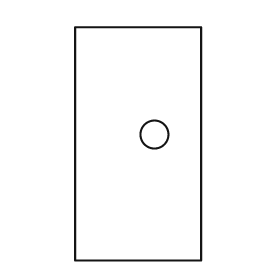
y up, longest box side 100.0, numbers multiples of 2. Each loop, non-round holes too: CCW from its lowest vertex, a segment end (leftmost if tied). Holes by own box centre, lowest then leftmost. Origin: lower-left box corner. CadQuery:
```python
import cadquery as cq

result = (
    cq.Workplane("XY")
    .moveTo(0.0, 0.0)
    .lineTo(54.0, 0.0)
    .lineTo(54.0, 100.0)
    .lineTo(0.0, 100.0)
    .close()
    .moveTo(34.0, 54.0)
    .circle(6.0)
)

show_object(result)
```